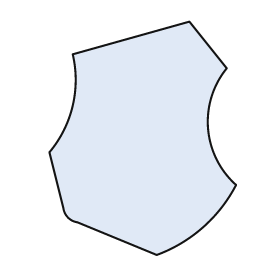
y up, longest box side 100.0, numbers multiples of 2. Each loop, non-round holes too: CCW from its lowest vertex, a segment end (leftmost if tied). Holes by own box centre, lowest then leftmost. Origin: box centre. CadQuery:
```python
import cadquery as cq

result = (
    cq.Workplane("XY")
    .moveTo(6.0, -50.0)
    .threePointArc((26.0, -38.0), (40.0, -20.0))
    .threePointArc((28.0, 4.0), (36.0, 30.0))
    .lineTo(20.0, 50.0)
    .lineTo(-30.0, 36.0)
    .threePointArc((-30.0, 14.0), (-40.0, -6.0))
    .lineTo(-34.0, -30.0)
    .threePointArc((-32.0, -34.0), (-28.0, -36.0))
    .close()
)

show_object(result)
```